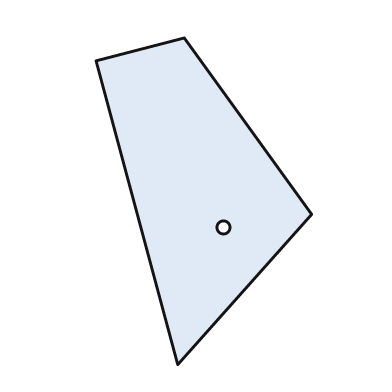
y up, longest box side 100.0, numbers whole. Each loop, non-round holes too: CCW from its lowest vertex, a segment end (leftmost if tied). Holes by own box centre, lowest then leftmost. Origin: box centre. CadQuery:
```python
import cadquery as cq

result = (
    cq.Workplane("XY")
    .moveTo(-8.0, -50.0)
    .lineTo(33.0, -4.0)
    .lineTo(-6.0, 50.0)
    .lineTo(-33.0, 43.0)
    .close()
    .moveTo(6.0, -8.0)
    .circle(2.0)
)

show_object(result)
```